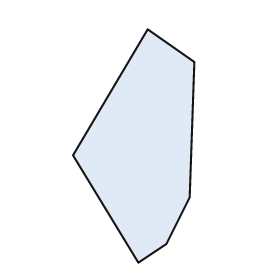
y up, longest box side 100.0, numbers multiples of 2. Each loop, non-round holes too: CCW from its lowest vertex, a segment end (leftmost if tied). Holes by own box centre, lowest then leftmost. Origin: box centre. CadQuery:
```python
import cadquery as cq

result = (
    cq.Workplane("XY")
    .moveTo(2.0, -50.0)
    .lineTo(14.0, -42.0)
    .lineTo(24.0, -22.0)
    .lineTo(26.0, 36.0)
    .lineTo(6.0, 50.0)
    .lineTo(-26.0, -4.0)
    .close()
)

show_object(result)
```